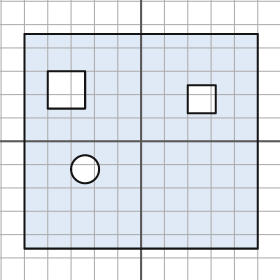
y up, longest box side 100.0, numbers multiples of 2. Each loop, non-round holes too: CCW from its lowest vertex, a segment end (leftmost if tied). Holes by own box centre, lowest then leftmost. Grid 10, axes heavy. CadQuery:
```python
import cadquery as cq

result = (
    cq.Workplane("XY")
    .moveTo(-50.0, -46.0)
    .lineTo(50.0, -46.0)
    .lineTo(50.0, 46.0)
    .lineTo(-50.0, 46.0)
    .close()
    .moveTo(-24.0, -12.0)
    .circle(6.0)
    .moveTo(20.0, 12.0)
    .lineTo(32.0, 12.0)
    .lineTo(32.0, 24.0)
    .lineTo(20.0, 24.0)
    .close()
    .moveTo(-40.0, 14.0)
    .lineTo(-24.0, 14.0)
    .lineTo(-24.0, 30.0)
    .lineTo(-40.0, 30.0)
    .close()
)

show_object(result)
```